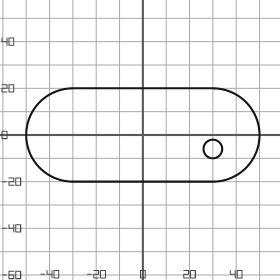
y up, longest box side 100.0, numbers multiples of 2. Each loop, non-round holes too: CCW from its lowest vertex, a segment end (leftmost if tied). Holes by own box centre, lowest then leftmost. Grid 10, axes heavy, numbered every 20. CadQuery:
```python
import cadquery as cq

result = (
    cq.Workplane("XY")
    .moveTo(-30.0, -20.0)
    .lineTo(30.0, -20.0)
    .threePointArc((50.0, 0.0), (30.0, 20.0))
    .lineTo(-30.0, 20.0)
    .threePointArc((-50.0, 0.0), (-30.0, -20.0))
    .close()
    .moveTo(30.0, -6.0)
    .circle(4.0)
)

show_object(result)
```